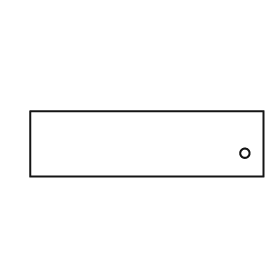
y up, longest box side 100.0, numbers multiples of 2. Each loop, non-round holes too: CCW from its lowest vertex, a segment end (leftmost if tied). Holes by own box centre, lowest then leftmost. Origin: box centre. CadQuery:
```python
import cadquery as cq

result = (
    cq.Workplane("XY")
    .moveTo(-50.0, -14.0)
    .lineTo(50.0, -14.0)
    .lineTo(50.0, 14.0)
    .lineTo(-50.0, 14.0)
    .close()
    .moveTo(42.0, -4.0)
    .circle(2.0)
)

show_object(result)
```